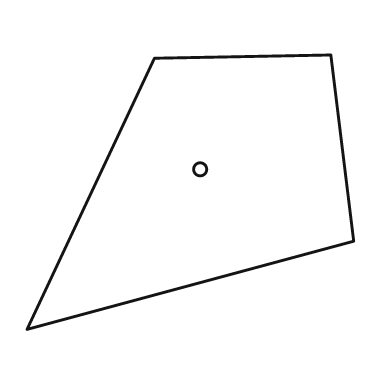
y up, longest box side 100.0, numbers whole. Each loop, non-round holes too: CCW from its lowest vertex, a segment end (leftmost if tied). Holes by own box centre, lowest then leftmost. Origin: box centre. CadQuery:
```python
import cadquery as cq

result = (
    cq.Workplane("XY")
    .moveTo(-50.0, -42.0)
    .lineTo(50.0, -15.0)
    .lineTo(43.0, 42.0)
    .lineTo(-11.0, 41.0)
    .close()
    .moveTo(3.0, 7.0)
    .circle(2.0)
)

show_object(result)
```